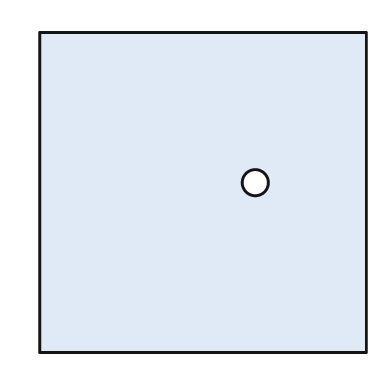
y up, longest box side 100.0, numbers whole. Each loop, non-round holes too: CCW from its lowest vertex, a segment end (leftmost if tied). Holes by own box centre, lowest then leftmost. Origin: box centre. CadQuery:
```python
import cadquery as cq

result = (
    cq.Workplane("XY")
    .moveTo(-50.0, -49.0)
    .lineTo(50.0, -49.0)
    .lineTo(50.0, 49.0)
    .lineTo(-50.0, 49.0)
    .close()
    .moveTo(16.0, 3.0)
    .circle(4.0)
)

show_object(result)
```